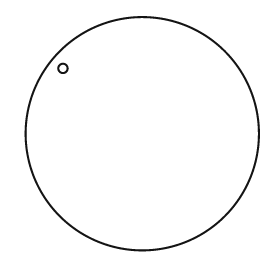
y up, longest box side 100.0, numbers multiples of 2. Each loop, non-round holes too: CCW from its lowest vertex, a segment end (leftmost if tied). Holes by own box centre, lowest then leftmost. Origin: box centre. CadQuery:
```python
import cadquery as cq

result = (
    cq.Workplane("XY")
    .moveTo(0.0, 0.0)
    .circle(50.0)
    .moveTo(-34.0, 28.0)
    .circle(2.0)
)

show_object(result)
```